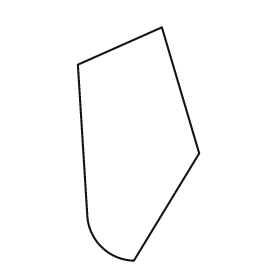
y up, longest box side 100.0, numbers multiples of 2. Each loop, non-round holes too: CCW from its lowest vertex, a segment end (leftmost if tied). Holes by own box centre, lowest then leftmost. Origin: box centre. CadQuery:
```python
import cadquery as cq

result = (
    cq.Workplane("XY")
    .moveTo(-2.0, -50.0)
    .lineTo(26.0, -4.0)
    .lineTo(10.0, 50.0)
    .lineTo(-26.0, 34.0)
    .lineTo(-22.0, -30.0)
    .threePointArc((-16.0, -44.0), (-2.0, -50.0))
    .close()
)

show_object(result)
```